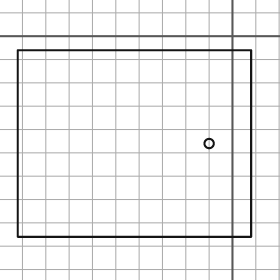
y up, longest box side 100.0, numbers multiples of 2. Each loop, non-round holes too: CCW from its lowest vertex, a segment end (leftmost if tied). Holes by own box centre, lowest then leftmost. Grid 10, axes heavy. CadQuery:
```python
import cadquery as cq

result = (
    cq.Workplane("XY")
    .moveTo(-92.0, -86.0)
    .lineTo(8.0, -86.0)
    .lineTo(8.0, -6.0)
    .lineTo(-92.0, -6.0)
    .close()
    .moveTo(-10.0, -46.0)
    .circle(2.0)
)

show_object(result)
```